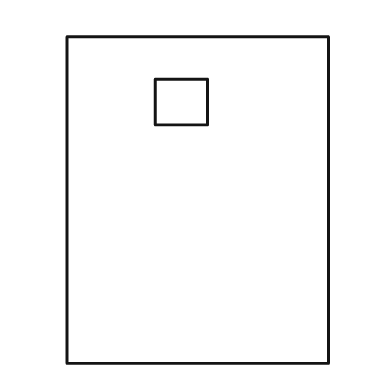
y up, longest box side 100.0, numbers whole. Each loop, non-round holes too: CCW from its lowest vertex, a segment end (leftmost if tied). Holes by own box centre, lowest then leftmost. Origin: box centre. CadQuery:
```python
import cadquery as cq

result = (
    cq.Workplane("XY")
    .moveTo(-40.0, -50.0)
    .lineTo(40.0, -50.0)
    .lineTo(40.0, 50.0)
    .lineTo(-40.0, 50.0)
    .close()
    .moveTo(-13.0, 23.0)
    .lineTo(3.0, 23.0)
    .lineTo(3.0, 37.0)
    .lineTo(-13.0, 37.0)
    .close()
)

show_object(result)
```